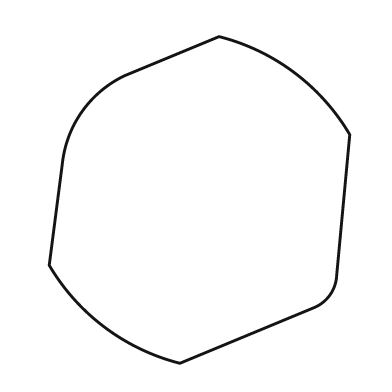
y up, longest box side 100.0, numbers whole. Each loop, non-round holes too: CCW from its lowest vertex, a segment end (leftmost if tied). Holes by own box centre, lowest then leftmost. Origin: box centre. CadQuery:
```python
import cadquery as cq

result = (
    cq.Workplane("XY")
    .moveTo(-6.0, -50.0)
    .lineTo(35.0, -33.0)
    .threePointArc((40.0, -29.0), (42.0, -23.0))
    .lineTo(46.0, 20.0)
    .threePointArc((29.0, 39.0), (6.0, 50.0))
    .lineTo(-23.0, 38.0)
    .threePointArc((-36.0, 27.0), (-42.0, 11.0))
    .lineTo(-46.0, -20.0)
    .threePointArc((-29.0, -39.0), (-6.0, -50.0))
    .close()
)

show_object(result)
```